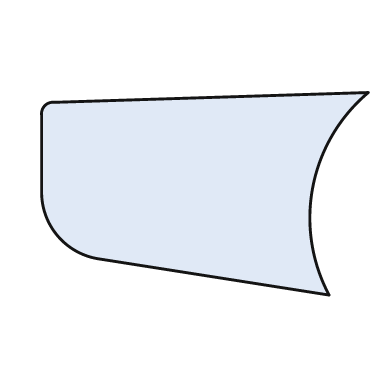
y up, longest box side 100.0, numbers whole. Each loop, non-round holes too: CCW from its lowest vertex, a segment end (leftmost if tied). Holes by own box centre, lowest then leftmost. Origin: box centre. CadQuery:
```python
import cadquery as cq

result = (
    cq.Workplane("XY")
    .moveTo(38.0, -31.0)
    .threePointArc((33.0, 2.0), (50.0, 31.0))
    .lineTo(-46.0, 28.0)
    .threePointArc((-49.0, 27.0), (-50.0, 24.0))
    .lineTo(-50.0, 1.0)
    .threePointArc((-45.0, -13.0), (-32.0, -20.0))
    .close()
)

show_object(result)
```